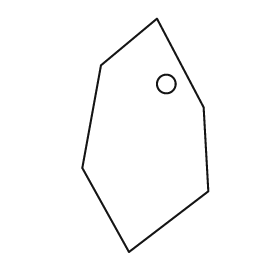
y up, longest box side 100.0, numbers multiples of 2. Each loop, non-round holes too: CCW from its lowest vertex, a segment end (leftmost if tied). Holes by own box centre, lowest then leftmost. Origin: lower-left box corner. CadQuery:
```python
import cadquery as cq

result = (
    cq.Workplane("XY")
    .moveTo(20.0, 0.0)
    .lineTo(54.0, 26.0)
    .lineTo(52.0, 62.0)
    .lineTo(32.0, 100.0)
    .lineTo(8.0, 80.0)
    .lineTo(0.0, 36.0)
    .close()
    .moveTo(36.0, 72.0)
    .circle(4.0)
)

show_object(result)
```